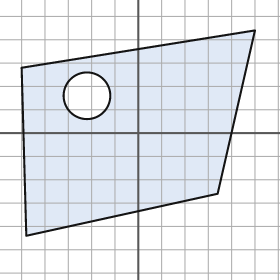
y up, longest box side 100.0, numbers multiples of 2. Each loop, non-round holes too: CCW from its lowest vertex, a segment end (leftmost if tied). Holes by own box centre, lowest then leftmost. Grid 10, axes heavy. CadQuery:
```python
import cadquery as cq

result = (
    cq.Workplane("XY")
    .moveTo(-48.0, -44.0)
    .lineTo(34.0, -26.0)
    .lineTo(50.0, 44.0)
    .lineTo(-50.0, 28.0)
    .close()
    .moveTo(-22.0, 16.0)
    .circle(10.0)
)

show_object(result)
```